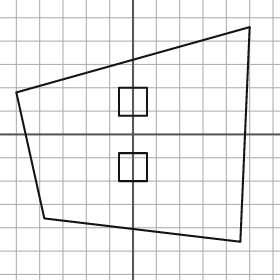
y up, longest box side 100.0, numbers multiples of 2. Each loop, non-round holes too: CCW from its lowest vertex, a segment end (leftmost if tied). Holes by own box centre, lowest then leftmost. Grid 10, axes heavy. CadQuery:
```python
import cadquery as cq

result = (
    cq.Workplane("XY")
    .moveTo(46.0, -46.0)
    .lineTo(50.0, 46.0)
    .lineTo(-50.0, 18.0)
    .lineTo(-38.0, -36.0)
    .close()
    .moveTo(-6.0, -20.0)
    .lineTo(6.0, -20.0)
    .lineTo(6.0, -8.0)
    .lineTo(-6.0, -8.0)
    .close()
    .moveTo(-6.0, 8.0)
    .lineTo(6.0, 8.0)
    .lineTo(6.0, 20.0)
    .lineTo(-6.0, 20.0)
    .close()
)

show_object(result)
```